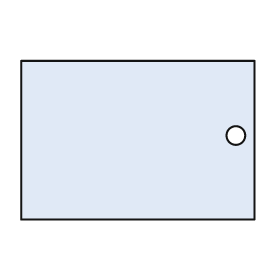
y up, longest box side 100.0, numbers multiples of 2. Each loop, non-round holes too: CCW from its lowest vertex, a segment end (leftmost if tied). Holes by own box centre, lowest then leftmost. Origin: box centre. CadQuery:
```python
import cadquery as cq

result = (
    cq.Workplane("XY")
    .moveTo(-50.0, -34.0)
    .lineTo(50.0, -34.0)
    .lineTo(50.0, 34.0)
    .lineTo(-50.0, 34.0)
    .close()
    .moveTo(42.0, 2.0)
    .circle(4.0)
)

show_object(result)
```